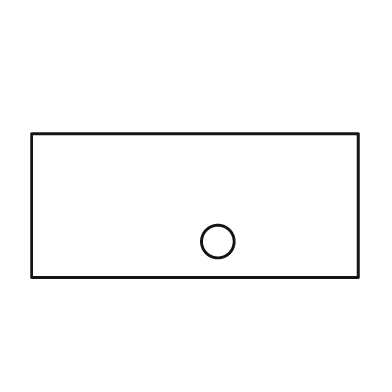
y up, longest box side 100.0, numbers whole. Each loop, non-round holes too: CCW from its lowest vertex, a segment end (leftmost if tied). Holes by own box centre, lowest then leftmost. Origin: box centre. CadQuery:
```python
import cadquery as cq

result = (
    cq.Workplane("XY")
    .moveTo(-50.0, -22.0)
    .lineTo(50.0, -22.0)
    .lineTo(50.0, 22.0)
    .lineTo(-50.0, 22.0)
    .close()
    .moveTo(7.0, -11.0)
    .circle(5.0)
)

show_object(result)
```